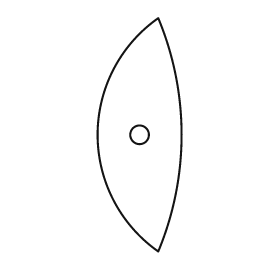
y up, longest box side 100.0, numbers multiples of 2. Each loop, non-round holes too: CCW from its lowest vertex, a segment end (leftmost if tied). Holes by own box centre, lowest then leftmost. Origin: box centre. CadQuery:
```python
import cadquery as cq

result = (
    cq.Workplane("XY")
    .moveTo(8.0, -50.0)
    .threePointArc((18.0, 0.0), (8.0, 50.0))
    .threePointArc((-18.0, 0.0), (8.0, -50.0))
    .close()
    .moveTo(0.0, 0.0)
    .circle(4.0)
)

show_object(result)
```